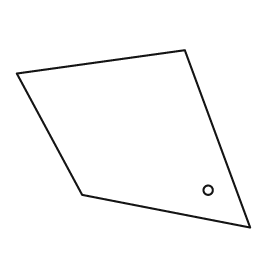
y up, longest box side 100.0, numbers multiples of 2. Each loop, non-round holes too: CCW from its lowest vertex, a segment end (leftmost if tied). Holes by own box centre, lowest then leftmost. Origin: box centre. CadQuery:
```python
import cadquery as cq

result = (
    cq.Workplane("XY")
    .moveTo(50.0, -38.0)
    .lineTo(22.0, 38.0)
    .lineTo(-50.0, 28.0)
    .lineTo(-22.0, -24.0)
    .close()
    .moveTo(32.0, -22.0)
    .circle(2.0)
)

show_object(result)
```